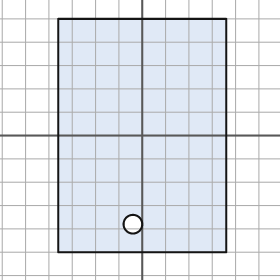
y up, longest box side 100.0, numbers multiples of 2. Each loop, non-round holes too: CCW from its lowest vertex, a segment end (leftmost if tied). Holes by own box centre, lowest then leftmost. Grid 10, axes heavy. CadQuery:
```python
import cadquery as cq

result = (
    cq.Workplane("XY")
    .moveTo(-36.0, -50.0)
    .lineTo(36.0, -50.0)
    .lineTo(36.0, 50.0)
    .lineTo(-36.0, 50.0)
    .close()
    .moveTo(-4.0, -38.0)
    .circle(4.0)
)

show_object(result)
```